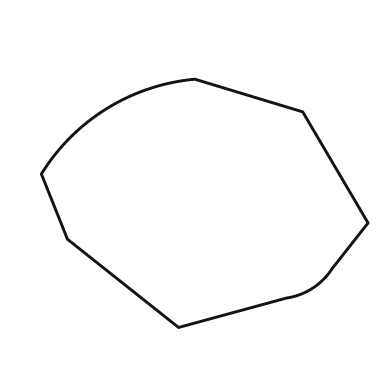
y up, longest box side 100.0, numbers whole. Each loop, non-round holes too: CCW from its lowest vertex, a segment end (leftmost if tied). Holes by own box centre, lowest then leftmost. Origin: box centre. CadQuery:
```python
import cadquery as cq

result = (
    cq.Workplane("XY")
    .moveTo(-8.0, -38.0)
    .lineTo(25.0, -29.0)
    .threePointArc((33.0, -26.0), (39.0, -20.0))
    .lineTo(50.0, -6.0)
    .lineTo(30.0, 28.0)
    .lineTo(-3.0, 38.0)
    .threePointArc((-30.0, 29.0), (-50.0, 9.0))
    .lineTo(-42.0, -11.0)
    .close()
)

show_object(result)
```